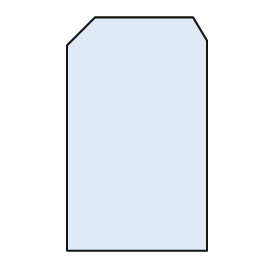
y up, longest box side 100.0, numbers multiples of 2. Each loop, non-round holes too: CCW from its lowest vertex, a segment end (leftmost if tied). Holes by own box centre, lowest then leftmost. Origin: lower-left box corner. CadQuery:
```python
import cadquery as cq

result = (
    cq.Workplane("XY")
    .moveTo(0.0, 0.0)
    .lineTo(60.0, 0.0)
    .lineTo(60.0, 90.0)
    .lineTo(54.0, 100.0)
    .lineTo(12.0, 100.0)
    .lineTo(0.0, 88.0)
    .close()
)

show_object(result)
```